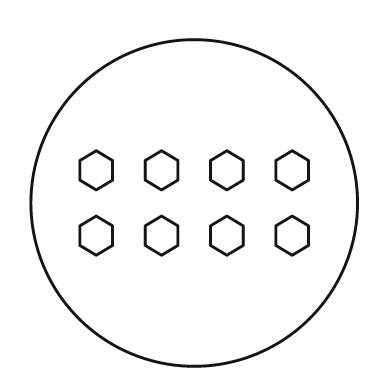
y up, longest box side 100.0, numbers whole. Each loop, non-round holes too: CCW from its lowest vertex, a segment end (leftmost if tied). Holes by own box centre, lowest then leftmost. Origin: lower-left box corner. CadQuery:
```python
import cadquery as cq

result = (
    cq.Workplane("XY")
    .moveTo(50.0, 50.0)
    .circle(50.0)
    .moveTo(20.0, 34.0)
    .lineTo(25.0, 37.0)
    .lineTo(25.0, 43.0)
    .lineTo(20.0, 46.0)
    .lineTo(15.0, 43.0)
    .lineTo(15.0, 37.0)
    .close()
    .moveTo(40.0, 34.0)
    .lineTo(45.0, 37.0)
    .lineTo(45.0, 43.0)
    .lineTo(40.0, 46.0)
    .lineTo(35.0, 43.0)
    .lineTo(35.0, 37.0)
    .close()
    .moveTo(60.0, 34.0)
    .lineTo(65.0, 37.0)
    .lineTo(65.0, 43.0)
    .lineTo(60.0, 46.0)
    .lineTo(55.0, 43.0)
    .lineTo(55.0, 37.0)
    .close()
    .moveTo(80.0, 34.0)
    .lineTo(85.0, 37.0)
    .lineTo(85.0, 43.0)
    .lineTo(80.0, 46.0)
    .lineTo(75.0, 43.0)
    .lineTo(75.0, 37.0)
    .close()
    .moveTo(20.0, 54.0)
    .lineTo(25.0, 57.0)
    .lineTo(25.0, 63.0)
    .lineTo(20.0, 66.0)
    .lineTo(15.0, 63.0)
    .lineTo(15.0, 57.0)
    .close()
    .moveTo(40.0, 54.0)
    .lineTo(45.0, 57.0)
    .lineTo(45.0, 63.0)
    .lineTo(40.0, 66.0)
    .lineTo(35.0, 63.0)
    .lineTo(35.0, 57.0)
    .close()
    .moveTo(60.0, 54.0)
    .lineTo(65.0, 57.0)
    .lineTo(65.0, 63.0)
    .lineTo(60.0, 66.0)
    .lineTo(55.0, 63.0)
    .lineTo(55.0, 57.0)
    .close()
    .moveTo(80.0, 54.0)
    .lineTo(85.0, 57.0)
    .lineTo(85.0, 63.0)
    .lineTo(80.0, 66.0)
    .lineTo(75.0, 63.0)
    .lineTo(75.0, 57.0)
    .close()
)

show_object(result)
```